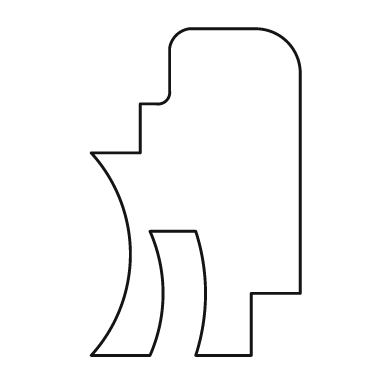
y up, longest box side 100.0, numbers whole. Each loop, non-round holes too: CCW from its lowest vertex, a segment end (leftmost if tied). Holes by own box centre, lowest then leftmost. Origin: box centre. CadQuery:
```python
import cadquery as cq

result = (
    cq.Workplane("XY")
    .moveTo(-32.0, -50.0)
    .lineTo(-14.0, -50.0)
    .threePointArc((-10.0, -31.0), (-14.0, -12.0))
    .lineTo(0.0, -12.0)
    .threePointArc((3.0, -31.0), (0.0, -50.0))
    .lineTo(17.0, -50.0)
    .lineTo(17.0, -31.0)
    .lineTo(32.0, -31.0)
    .lineTo(32.0, 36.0)
    .threePointArc((28.0, 46.0), (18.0, 50.0))
    .lineTo(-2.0, 50.0)
    .threePointArc((-6.0, 48.0), (-8.0, 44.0))
    .lineTo(-8.0, 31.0)
    .threePointArc((-9.0, 28.0), (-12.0, 27.0))
    .lineTo(-17.0, 27.0)
    .lineTo(-17.0, 12.0)
    .lineTo(-32.0, 12.0)
    .threePointArc((-20.0, -19.0), (-32.0, -50.0))
    .close()
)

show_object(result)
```